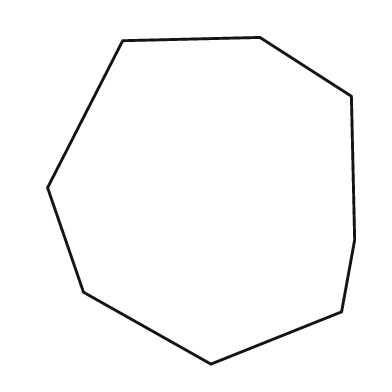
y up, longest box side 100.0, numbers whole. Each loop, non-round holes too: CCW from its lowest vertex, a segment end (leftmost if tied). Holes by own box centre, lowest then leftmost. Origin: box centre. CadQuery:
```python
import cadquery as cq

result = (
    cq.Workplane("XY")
    .moveTo(3.0, -50.0)
    .lineTo(43.0, -34.0)
    .lineTo(47.0, -12.0)
    .lineTo(46.0, 32.0)
    .lineTo(18.0, 50.0)
    .lineTo(-24.0, 49.0)
    .lineTo(-47.0, 4.0)
    .lineTo(-36.0, -28.0)
    .close()
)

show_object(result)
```